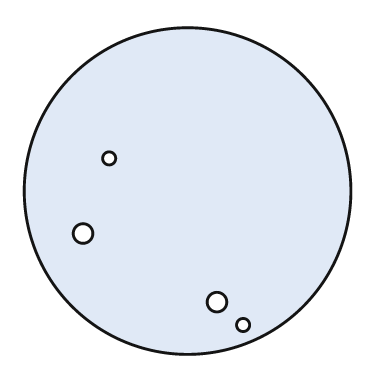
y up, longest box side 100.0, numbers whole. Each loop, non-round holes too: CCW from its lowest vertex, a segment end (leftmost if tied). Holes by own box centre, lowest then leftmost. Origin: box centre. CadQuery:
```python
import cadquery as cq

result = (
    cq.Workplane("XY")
    .moveTo(0.0, 0.0)
    .circle(50.0)
    .moveTo(17.0, -41.0)
    .circle(2.0)
    .moveTo(9.0, -34.0)
    .circle(3.0)
    .moveTo(-32.0, -13.0)
    .circle(3.0)
    .moveTo(-24.0, 10.0)
    .circle(2.0)
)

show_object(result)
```